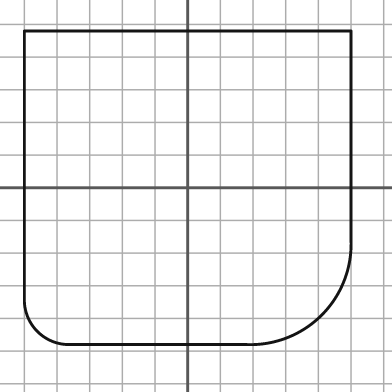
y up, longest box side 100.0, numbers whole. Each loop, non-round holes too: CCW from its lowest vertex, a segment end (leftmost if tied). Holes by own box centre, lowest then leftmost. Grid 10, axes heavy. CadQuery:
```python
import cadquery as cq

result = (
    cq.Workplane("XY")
    .moveTo(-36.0, -48.0)
    .lineTo(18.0, -48.0)
    .threePointArc((41.0, -39.0), (50.0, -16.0))
    .lineTo(50.0, 48.0)
    .lineTo(-50.0, 48.0)
    .lineTo(-50.0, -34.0)
    .threePointArc((-46.0, -44.0), (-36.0, -48.0))
    .close()
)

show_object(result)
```